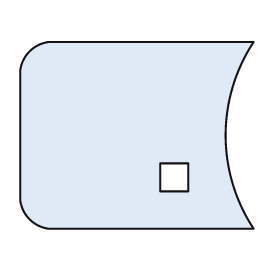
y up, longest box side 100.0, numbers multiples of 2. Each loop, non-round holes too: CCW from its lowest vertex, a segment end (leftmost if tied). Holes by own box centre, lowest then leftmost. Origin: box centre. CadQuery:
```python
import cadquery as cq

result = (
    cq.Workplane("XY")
    .moveTo(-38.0, -40.0)
    .lineTo(50.0, -40.0)
    .threePointArc((38.0, 0.0), (50.0, 40.0))
    .lineTo(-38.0, 40.0)
    .threePointArc((-46.0, 36.0), (-50.0, 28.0))
    .lineTo(-50.0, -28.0)
    .threePointArc((-46.0, -36.0), (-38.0, -40.0))
    .close()
    .moveTo(10.0, -24.0)
    .lineTo(22.0, -24.0)
    .lineTo(22.0, -12.0)
    .lineTo(10.0, -12.0)
    .close()
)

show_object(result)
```